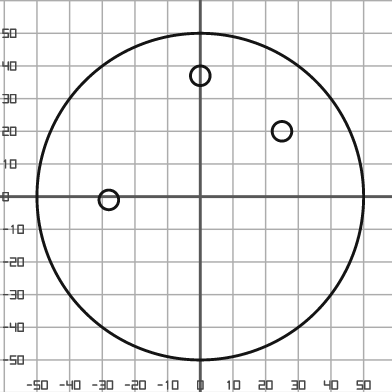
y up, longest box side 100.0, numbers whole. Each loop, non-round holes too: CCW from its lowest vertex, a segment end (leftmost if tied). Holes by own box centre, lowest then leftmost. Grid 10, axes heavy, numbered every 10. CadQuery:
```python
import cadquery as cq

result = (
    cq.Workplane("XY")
    .moveTo(0.0, 0.0)
    .circle(50.0)
    .moveTo(-28.0, -1.0)
    .circle(3.0)
    .moveTo(25.0, 20.0)
    .circle(3.0)
    .moveTo(0.0, 37.0)
    .circle(3.0)
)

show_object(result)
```